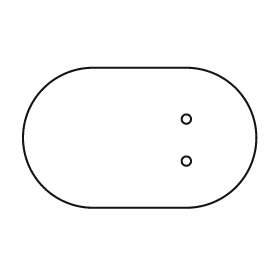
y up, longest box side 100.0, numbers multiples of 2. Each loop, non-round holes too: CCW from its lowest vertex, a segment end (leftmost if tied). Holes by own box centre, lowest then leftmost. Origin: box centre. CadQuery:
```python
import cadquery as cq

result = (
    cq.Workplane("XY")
    .moveTo(-20.0, -30.0)
    .lineTo(20.0, -30.0)
    .threePointArc((50.0, 0.0), (20.0, 30.0))
    .lineTo(-20.0, 30.0)
    .threePointArc((-50.0, 0.0), (-20.0, -30.0))
    .close()
    .moveTo(20.0, -10.0)
    .circle(2.0)
    .moveTo(20.0, 8.0)
    .circle(2.0)
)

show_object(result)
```